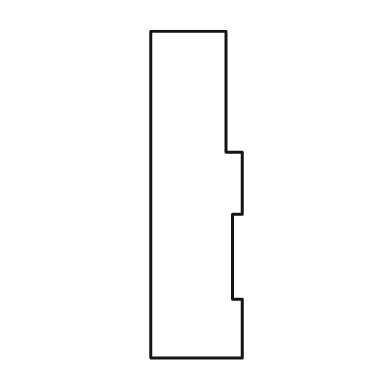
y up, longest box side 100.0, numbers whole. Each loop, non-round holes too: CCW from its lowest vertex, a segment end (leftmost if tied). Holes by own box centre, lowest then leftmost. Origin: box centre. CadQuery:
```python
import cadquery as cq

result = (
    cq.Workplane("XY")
    .moveTo(-14.0, -50.0)
    .lineTo(14.0, -50.0)
    .lineTo(14.0, -32.0)
    .lineTo(11.0, -32.0)
    .lineTo(11.0, -6.0)
    .lineTo(14.0, -6.0)
    .lineTo(14.0, 13.0)
    .lineTo(9.0, 13.0)
    .lineTo(9.0, 50.0)
    .lineTo(-14.0, 50.0)
    .close()
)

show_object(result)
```